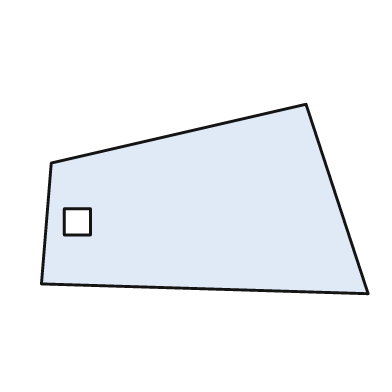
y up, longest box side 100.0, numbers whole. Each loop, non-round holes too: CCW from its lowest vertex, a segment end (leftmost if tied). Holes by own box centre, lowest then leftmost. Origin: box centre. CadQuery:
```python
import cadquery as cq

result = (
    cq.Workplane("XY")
    .moveTo(50.0, -29.0)
    .lineTo(31.0, 29.0)
    .lineTo(-47.0, 11.0)
    .lineTo(-50.0, -26.0)
    .close()
    .moveTo(-43.0, -11.0)
    .lineTo(-35.0, -11.0)
    .lineTo(-35.0, -3.0)
    .lineTo(-43.0, -3.0)
    .close()
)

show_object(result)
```